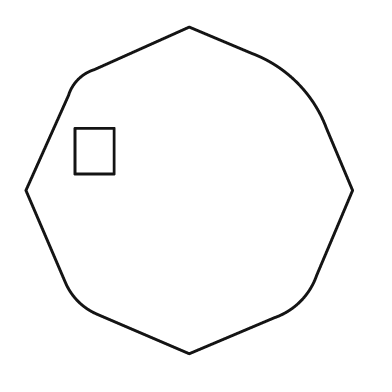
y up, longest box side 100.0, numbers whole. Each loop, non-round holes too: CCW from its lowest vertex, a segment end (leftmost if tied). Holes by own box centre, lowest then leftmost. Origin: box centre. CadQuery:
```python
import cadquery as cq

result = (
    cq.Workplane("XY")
    .moveTo(0.0, -50.0)
    .lineTo(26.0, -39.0)
    .threePointArc((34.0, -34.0), (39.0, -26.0))
    .lineTo(50.0, 0.0)
    .lineTo(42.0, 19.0)
    .threePointArc((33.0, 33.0), (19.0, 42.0))
    .lineTo(0.0, 50.0)
    .lineTo(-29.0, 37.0)
    .threePointArc((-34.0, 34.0), (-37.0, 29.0))
    .lineTo(-50.0, 0.0)
    .lineTo(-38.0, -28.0)
    .threePointArc((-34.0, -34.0), (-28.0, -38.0))
    .close()
    .moveTo(-35.0, 5.0)
    .lineTo(-23.0, 5.0)
    .lineTo(-23.0, 19.0)
    .lineTo(-35.0, 19.0)
    .close()
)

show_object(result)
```